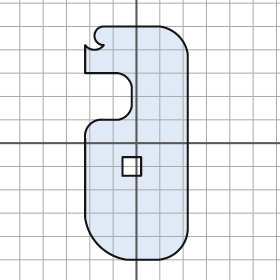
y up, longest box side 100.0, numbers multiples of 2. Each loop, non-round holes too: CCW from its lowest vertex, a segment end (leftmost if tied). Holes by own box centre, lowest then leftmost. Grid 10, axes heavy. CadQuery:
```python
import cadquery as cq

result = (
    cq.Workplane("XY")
    .moveTo(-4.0, -50.0)
    .lineTo(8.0, -50.0)
    .threePointArc((18.0, -46.0), (22.0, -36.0))
    .lineTo(22.0, 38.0)
    .threePointArc((18.0, 46.0), (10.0, 50.0))
    .lineTo(-14.0, 50.0)
    .threePointArc((-18.0, 46.0), (-14.0, 42.0))
    .threePointArc((-18.0, 40.0), (-22.0, 42.0))
    .lineTo(-22.0, 30.0)
    .lineTo(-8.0, 30.0)
    .threePointArc((-4.0, 28.0), (-2.0, 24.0))
    .lineTo(-2.0, 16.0)
    .threePointArc((-4.0, 12.0), (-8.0, 10.0))
    .lineTo(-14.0, 10.0)
    .threePointArc((-20.0, 8.0), (-22.0, 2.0))
    .lineTo(-22.0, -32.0)
    .threePointArc((-16.0, -44.0), (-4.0, -50.0))
    .close()
    .moveTo(-6.0, -14.0)
    .lineTo(2.0, -14.0)
    .lineTo(2.0, -6.0)
    .lineTo(-6.0, -6.0)
    .close()
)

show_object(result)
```